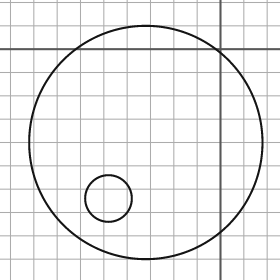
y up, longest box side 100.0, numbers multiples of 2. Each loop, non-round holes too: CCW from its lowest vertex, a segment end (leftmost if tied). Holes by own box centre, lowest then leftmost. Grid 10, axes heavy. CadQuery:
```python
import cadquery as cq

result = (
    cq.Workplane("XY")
    .moveTo(-32.0, -40.0)
    .circle(50.0)
    .moveTo(-48.0, -64.0)
    .circle(10.0)
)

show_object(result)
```